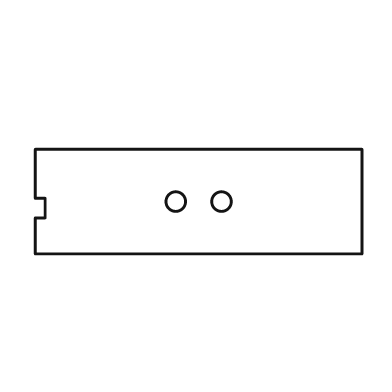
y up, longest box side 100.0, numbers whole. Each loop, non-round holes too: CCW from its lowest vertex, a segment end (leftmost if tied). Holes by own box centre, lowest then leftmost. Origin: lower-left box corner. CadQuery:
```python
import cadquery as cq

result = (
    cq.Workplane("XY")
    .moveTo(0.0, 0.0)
    .lineTo(100.0, 0.0)
    .lineTo(100.0, 32.0)
    .lineTo(0.0, 32.0)
    .lineTo(0.0, 17.0)
    .lineTo(3.0, 17.0)
    .lineTo(3.0, 11.0)
    .lineTo(0.0, 11.0)
    .close()
    .moveTo(43.0, 16.0)
    .circle(3.0)
    .moveTo(57.0, 16.0)
    .circle(3.0)
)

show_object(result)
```